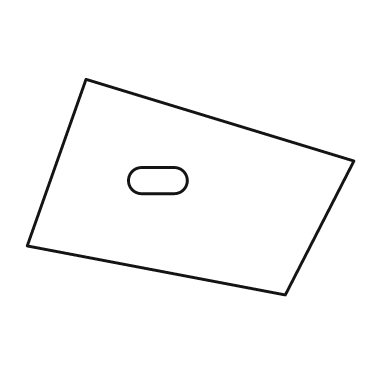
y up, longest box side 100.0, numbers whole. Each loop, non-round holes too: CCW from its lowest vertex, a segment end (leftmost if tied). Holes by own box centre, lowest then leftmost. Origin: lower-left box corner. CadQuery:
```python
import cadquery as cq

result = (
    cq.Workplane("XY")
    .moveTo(79.0, 0.0)
    .lineTo(100.0, 41.0)
    .lineTo(18.0, 66.0)
    .lineTo(0.0, 15.0)
    .close()
    .moveTo(35.0, 31.0)
    .lineTo(45.0, 31.0)
    .threePointArc((49.0, 35.0), (45.0, 39.0))
    .lineTo(35.0, 39.0)
    .threePointArc((31.0, 35.0), (35.0, 31.0))
    .close()
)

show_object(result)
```